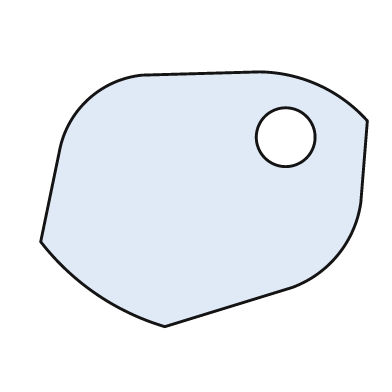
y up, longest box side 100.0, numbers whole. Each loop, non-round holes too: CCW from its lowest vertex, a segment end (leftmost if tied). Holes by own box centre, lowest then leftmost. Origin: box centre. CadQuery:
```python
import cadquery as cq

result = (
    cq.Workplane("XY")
    .moveTo(-12.0, -39.0)
    .lineTo(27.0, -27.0)
    .threePointArc((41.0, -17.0), (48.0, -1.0))
    .lineTo(50.0, 24.0)
    .threePointArc((35.0, 35.0), (17.0, 39.0))
    .lineTo(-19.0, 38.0)
    .threePointArc((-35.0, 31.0), (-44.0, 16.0))
    .lineTo(-50.0, -13.0)
    .threePointArc((-33.0, -29.0), (-12.0, -39.0))
    .close()
    .moveTo(25.0, 19.0)
    .circle(9.0)
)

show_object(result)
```